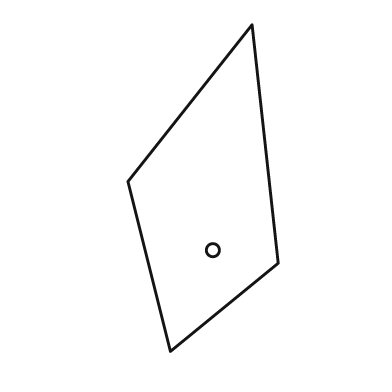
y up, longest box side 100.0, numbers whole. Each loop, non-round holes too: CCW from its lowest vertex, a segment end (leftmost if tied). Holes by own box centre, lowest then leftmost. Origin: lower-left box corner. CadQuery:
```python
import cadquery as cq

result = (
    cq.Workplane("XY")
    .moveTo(13.0, 0.0)
    .lineTo(46.0, 27.0)
    .lineTo(38.0, 100.0)
    .lineTo(0.0, 52.0)
    .close()
    .moveTo(26.0, 31.0)
    .circle(2.0)
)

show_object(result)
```